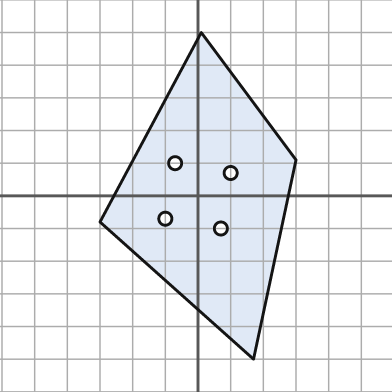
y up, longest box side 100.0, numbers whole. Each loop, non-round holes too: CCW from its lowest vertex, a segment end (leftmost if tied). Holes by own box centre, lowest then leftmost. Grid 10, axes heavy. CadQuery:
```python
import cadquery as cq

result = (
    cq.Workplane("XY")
    .moveTo(17.0, -50.0)
    .lineTo(30.0, 11.0)
    .lineTo(1.0, 50.0)
    .lineTo(-30.0, -8.0)
    .close()
    .moveTo(7.0, -10.0)
    .circle(2.0)
    .moveTo(-10.0, -7.0)
    .circle(2.0)
    .moveTo(10.0, 7.0)
    .circle(2.0)
    .moveTo(-7.0, 10.0)
    .circle(2.0)
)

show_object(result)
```